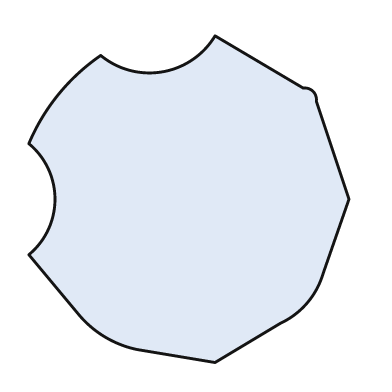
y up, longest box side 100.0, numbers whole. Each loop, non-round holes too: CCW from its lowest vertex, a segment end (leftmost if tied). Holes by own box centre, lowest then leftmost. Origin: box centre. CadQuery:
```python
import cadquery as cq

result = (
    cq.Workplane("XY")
    .moveTo(8.0, -50.0)
    .lineTo(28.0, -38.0)
    .threePointArc((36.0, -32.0), (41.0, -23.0))
    .lineTo(49.0, 0.0)
    .lineTo(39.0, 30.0)
    .threePointArc((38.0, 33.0), (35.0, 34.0))
    .lineTo(8.0, 50.0)
    .threePointArc((-8.0, 39.0), (-27.0, 44.0))
    .threePointArc((-40.0, 32.0), (-49.0, 17.0))
    .threePointArc((-41.0, 0.0), (-49.0, -17.0))
    .lineTo(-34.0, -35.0)
    .threePointArc((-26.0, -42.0), (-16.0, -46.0))
    .close()
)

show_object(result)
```